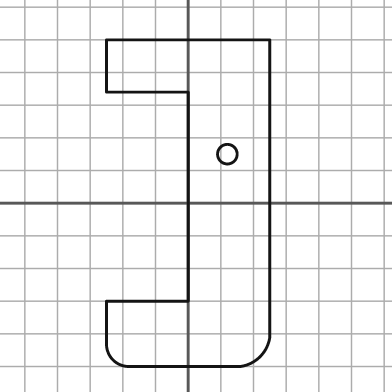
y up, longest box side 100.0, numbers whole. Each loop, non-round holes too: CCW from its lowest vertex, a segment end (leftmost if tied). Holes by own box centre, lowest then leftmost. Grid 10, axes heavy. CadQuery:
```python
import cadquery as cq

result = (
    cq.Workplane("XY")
    .moveTo(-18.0, -50.0)
    .lineTo(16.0, -50.0)
    .threePointArc((22.0, -47.0), (25.0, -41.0))
    .lineTo(25.0, 50.0)
    .lineTo(-25.0, 50.0)
    .lineTo(-25.0, 34.0)
    .lineTo(0.0, 34.0)
    .lineTo(0.0, -30.0)
    .lineTo(-25.0, -30.0)
    .lineTo(-25.0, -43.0)
    .threePointArc((-23.0, -48.0), (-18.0, -50.0))
    .close()
    .moveTo(12.0, 15.0)
    .circle(3.0)
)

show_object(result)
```